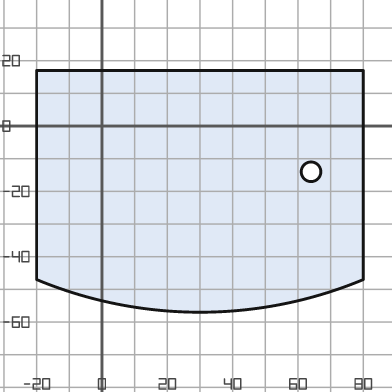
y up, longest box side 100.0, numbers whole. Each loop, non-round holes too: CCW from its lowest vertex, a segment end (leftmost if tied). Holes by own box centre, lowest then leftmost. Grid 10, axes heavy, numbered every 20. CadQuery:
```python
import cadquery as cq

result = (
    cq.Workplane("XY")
    .moveTo(-20.0, -47.0)
    .threePointArc((30.0, -57.0), (80.0, -47.0))
    .lineTo(80.0, 17.0)
    .lineTo(-20.0, 17.0)
    .close()
    .moveTo(64.0, -14.0)
    .circle(3.0)
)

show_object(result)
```